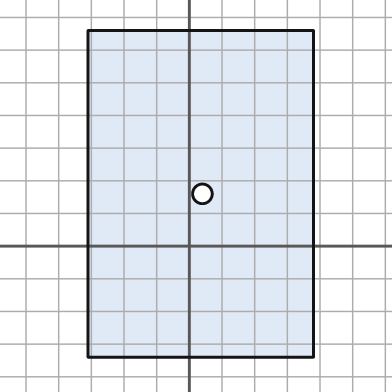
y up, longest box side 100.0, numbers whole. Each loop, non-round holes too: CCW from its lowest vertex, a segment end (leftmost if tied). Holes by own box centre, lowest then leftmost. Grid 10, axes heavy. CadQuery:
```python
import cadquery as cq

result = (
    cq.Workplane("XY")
    .moveTo(-31.0, -34.0)
    .lineTo(38.0, -34.0)
    .lineTo(38.0, 66.0)
    .lineTo(-31.0, 66.0)
    .close()
    .moveTo(4.0, 16.0)
    .circle(3.0)
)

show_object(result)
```